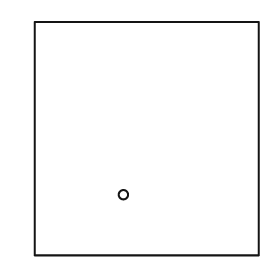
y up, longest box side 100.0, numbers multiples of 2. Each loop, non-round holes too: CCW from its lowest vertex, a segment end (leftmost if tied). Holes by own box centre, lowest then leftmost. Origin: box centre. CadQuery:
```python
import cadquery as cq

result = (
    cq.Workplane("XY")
    .moveTo(-48.0, -50.0)
    .lineTo(48.0, -50.0)
    .lineTo(48.0, 50.0)
    .lineTo(-48.0, 50.0)
    .close()
    .moveTo(-10.0, -24.0)
    .circle(2.0)
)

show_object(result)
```